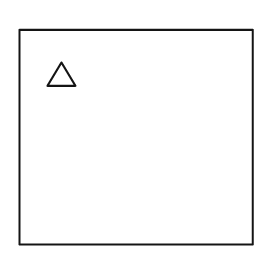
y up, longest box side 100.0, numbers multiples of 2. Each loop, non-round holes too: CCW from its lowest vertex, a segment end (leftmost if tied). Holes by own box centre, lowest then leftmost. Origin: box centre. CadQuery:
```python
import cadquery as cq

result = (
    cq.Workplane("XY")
    .moveTo(-50.0, -46.0)
    .lineTo(50.0, -46.0)
    .lineTo(50.0, 46.0)
    .lineTo(-50.0, 46.0)
    .close()
    .moveTo(-38.0, 22.0)
    .lineTo(-26.0, 22.0)
    .lineTo(-32.0, 32.0)
    .close()
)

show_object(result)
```